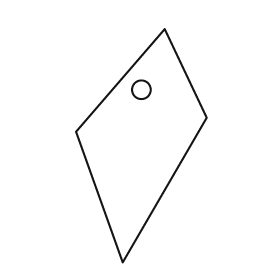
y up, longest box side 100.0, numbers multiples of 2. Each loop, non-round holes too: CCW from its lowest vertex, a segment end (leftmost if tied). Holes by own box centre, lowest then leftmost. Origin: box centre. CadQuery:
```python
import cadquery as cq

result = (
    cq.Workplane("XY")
    .moveTo(-8.0, -50.0)
    .lineTo(28.0, 12.0)
    .lineTo(10.0, 50.0)
    .lineTo(-28.0, 6.0)
    .close()
    .moveTo(0.0, 24.0)
    .circle(4.0)
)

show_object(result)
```